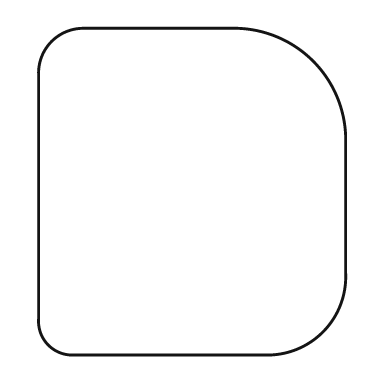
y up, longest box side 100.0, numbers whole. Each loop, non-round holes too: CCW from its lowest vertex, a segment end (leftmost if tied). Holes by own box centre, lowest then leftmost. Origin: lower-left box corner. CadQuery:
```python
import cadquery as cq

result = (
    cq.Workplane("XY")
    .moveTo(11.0, 0.0)
    .lineTo(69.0, 0.0)
    .threePointArc((87.0, 7.0), (94.0, 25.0))
    .lineTo(94.0, 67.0)
    .threePointArc((84.0, 90.0), (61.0, 100.0))
    .lineTo(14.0, 100.0)
    .threePointArc((4.0, 96.0), (0.0, 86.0))
    .lineTo(0.0, 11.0)
    .threePointArc((3.0, 3.0), (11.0, 0.0))
    .close()
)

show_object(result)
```